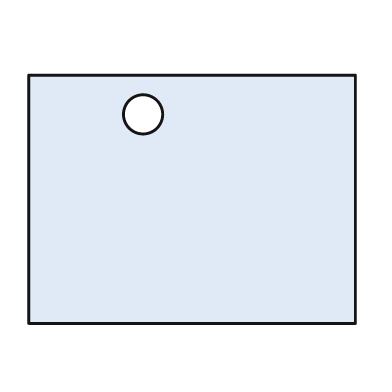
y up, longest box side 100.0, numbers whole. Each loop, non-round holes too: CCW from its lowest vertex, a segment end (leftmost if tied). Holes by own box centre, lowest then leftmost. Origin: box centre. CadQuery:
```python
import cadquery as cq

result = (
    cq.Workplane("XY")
    .moveTo(-50.0, -38.0)
    .lineTo(50.0, -38.0)
    .lineTo(50.0, 38.0)
    .lineTo(-50.0, 38.0)
    .close()
    .moveTo(-15.0, 26.0)
    .circle(6.0)
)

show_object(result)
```